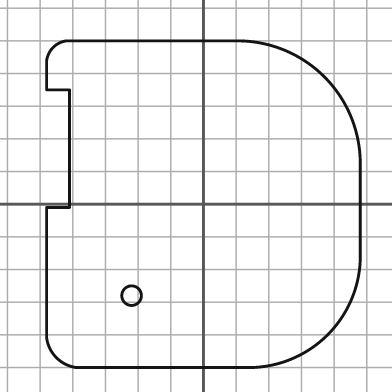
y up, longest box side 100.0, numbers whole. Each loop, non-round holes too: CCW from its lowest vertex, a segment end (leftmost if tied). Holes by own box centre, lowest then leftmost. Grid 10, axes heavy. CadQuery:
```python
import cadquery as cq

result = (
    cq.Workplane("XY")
    .moveTo(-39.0, -50.0)
    .lineTo(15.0, -50.0)
    .threePointArc((38.0, -40.0), (48.0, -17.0))
    .lineTo(48.0, 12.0)
    .threePointArc((37.0, 39.0), (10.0, 50.0))
    .lineTo(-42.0, 50.0)
    .threePointArc((-46.0, 48.0), (-48.0, 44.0))
    .lineTo(-48.0, 35.0)
    .lineTo(-41.0, 35.0)
    .lineTo(-41.0, -1.0)
    .lineTo(-48.0, -1.0)
    .lineTo(-48.0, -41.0)
    .threePointArc((-45.0, -47.0), (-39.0, -50.0))
    .close()
    .moveTo(-22.0, -28.0)
    .circle(3.0)
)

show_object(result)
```